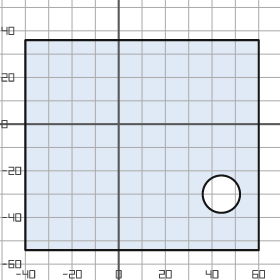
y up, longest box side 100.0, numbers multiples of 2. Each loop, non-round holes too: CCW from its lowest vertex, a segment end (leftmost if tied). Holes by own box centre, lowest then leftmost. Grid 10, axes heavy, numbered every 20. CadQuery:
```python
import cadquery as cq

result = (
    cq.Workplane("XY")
    .moveTo(-40.0, -54.0)
    .lineTo(60.0, -54.0)
    .lineTo(60.0, 36.0)
    .lineTo(-40.0, 36.0)
    .close()
    .moveTo(44.0, -30.0)
    .circle(8.0)
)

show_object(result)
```